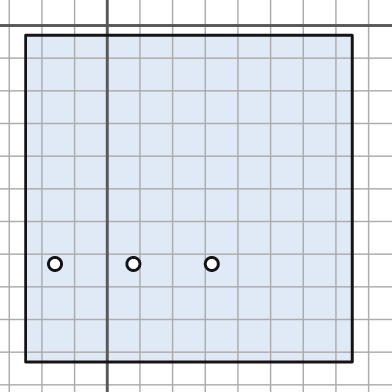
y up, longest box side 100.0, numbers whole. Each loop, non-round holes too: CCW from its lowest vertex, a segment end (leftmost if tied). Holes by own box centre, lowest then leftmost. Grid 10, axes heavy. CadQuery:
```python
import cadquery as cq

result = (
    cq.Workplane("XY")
    .moveTo(-25.0, -103.0)
    .lineTo(75.0, -103.0)
    .lineTo(75.0, -3.0)
    .lineTo(-25.0, -3.0)
    .close()
    .moveTo(-16.0, -73.0)
    .circle(2.0)
    .moveTo(8.0, -73.0)
    .circle(2.0)
    .moveTo(32.0, -73.0)
    .circle(2.0)
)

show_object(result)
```